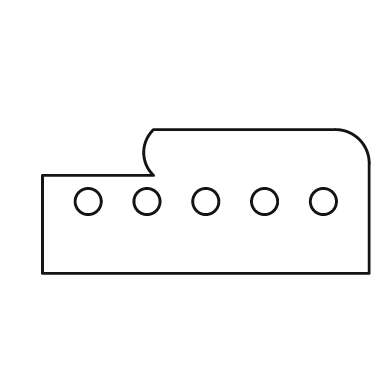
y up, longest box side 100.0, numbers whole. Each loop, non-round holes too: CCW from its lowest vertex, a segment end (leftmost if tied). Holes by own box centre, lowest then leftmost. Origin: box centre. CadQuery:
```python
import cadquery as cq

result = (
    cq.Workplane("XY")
    .moveTo(-50.0, -22.0)
    .lineTo(50.0, -22.0)
    .lineTo(50.0, 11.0)
    .threePointArc((47.0, 19.0), (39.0, 22.0))
    .lineTo(-16.0, 22.0)
    .threePointArc((-19.0, 15.0), (-16.0, 8.0))
    .lineTo(-50.0, 8.0)
    .close()
    .moveTo(-36.0, 0.0)
    .circle(4.0)
    .moveTo(-18.0, 0.0)
    .circle(4.0)
    .moveTo(0.0, 0.0)
    .circle(4.0)
    .moveTo(18.0, 0.0)
    .circle(4.0)
    .moveTo(36.0, 0.0)
    .circle(4.0)
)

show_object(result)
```